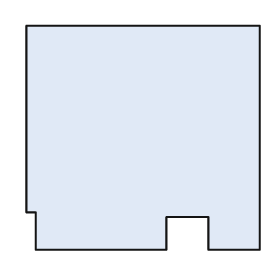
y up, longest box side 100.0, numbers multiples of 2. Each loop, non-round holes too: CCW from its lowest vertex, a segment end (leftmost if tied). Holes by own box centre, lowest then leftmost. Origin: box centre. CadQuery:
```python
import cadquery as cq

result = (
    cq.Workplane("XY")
    .moveTo(-46.0, -48.0)
    .lineTo(10.0, -48.0)
    .lineTo(10.0, -34.0)
    .lineTo(28.0, -34.0)
    .lineTo(28.0, -48.0)
    .lineTo(50.0, -48.0)
    .lineTo(50.0, 48.0)
    .lineTo(-50.0, 48.0)
    .lineTo(-50.0, -32.0)
    .lineTo(-46.0, -32.0)
    .close()
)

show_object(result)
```